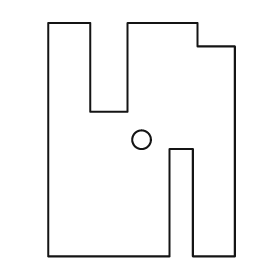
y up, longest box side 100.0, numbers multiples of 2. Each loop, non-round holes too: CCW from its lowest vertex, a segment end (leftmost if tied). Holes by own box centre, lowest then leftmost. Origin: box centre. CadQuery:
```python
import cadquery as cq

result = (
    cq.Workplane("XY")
    .moveTo(-40.0, -50.0)
    .lineTo(12.0, -50.0)
    .lineTo(12.0, -4.0)
    .lineTo(22.0, -4.0)
    .lineTo(22.0, -50.0)
    .lineTo(40.0, -50.0)
    .lineTo(40.0, 40.0)
    .lineTo(24.0, 40.0)
    .lineTo(24.0, 50.0)
    .lineTo(-6.0, 50.0)
    .lineTo(-6.0, 12.0)
    .lineTo(-22.0, 12.0)
    .lineTo(-22.0, 50.0)
    .lineTo(-40.0, 50.0)
    .close()
    .moveTo(0.0, 0.0)
    .circle(4.0)
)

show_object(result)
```